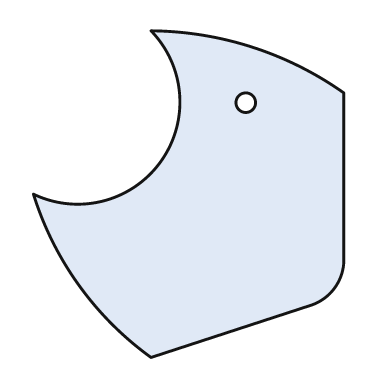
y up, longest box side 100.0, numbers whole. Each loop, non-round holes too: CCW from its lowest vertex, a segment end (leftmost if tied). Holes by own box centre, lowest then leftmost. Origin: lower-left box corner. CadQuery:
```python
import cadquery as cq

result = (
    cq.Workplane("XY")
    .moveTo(36.0, 0.0)
    .lineTo(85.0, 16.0)
    .threePointArc((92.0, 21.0), (95.0, 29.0))
    .lineTo(95.0, 81.0)
    .threePointArc((67.0, 95.0), (36.0, 100.0))
    .threePointArc((39.0, 60.0), (0.0, 50.0))
    .threePointArc((14.0, 22.0), (36.0, 0.0))
    .close()
    .moveTo(65.0, 78.0)
    .circle(3.0)
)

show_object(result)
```